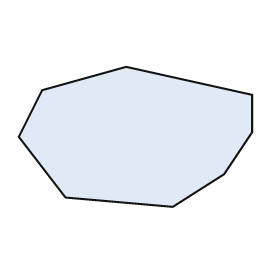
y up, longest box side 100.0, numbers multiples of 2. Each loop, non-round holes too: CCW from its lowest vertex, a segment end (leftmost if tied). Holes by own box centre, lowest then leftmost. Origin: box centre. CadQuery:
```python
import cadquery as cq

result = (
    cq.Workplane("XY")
    .moveTo(16.0, -30.0)
    .lineTo(38.0, -16.0)
    .lineTo(50.0, 2.0)
    .lineTo(50.0, 18.0)
    .lineTo(-4.0, 30.0)
    .lineTo(-40.0, 20.0)
    .lineTo(-50.0, 0.0)
    .lineTo(-30.0, -26.0)
    .close()
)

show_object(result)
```